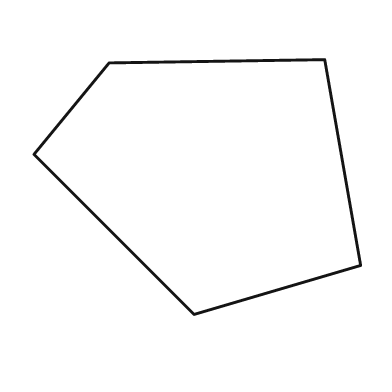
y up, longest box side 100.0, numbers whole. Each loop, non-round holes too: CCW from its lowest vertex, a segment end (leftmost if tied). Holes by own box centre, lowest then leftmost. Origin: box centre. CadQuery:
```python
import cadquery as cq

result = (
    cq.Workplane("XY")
    .moveTo(-1.0, -39.0)
    .lineTo(50.0, -24.0)
    .lineTo(39.0, 39.0)
    .lineTo(-27.0, 38.0)
    .lineTo(-50.0, 10.0)
    .close()
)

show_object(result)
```